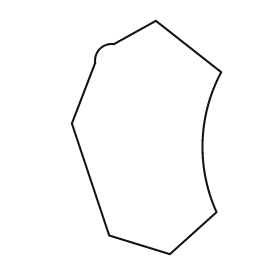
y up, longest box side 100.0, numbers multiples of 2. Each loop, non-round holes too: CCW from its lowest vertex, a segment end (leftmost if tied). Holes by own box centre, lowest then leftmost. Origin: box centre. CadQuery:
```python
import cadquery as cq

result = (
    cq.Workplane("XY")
    .moveTo(10.0, -50.0)
    .lineTo(30.0, -32.0)
    .threePointArc((24.0, -2.0), (32.0, 28.0))
    .lineTo(4.0, 50.0)
    .lineTo(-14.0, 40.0)
    .threePointArc((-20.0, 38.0), (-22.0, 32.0))
    .lineTo(-32.0, 6.0)
    .lineTo(-16.0, -42.0)
    .close()
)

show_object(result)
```